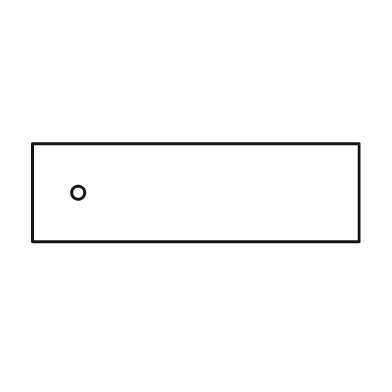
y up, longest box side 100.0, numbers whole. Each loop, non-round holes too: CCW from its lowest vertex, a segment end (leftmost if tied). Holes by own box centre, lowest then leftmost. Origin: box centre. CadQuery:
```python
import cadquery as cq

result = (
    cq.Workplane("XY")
    .moveTo(-50.0, -15.0)
    .lineTo(50.0, -15.0)
    .lineTo(50.0, 15.0)
    .lineTo(-50.0, 15.0)
    .close()
    .moveTo(-36.0, 0.0)
    .circle(2.0)
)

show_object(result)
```